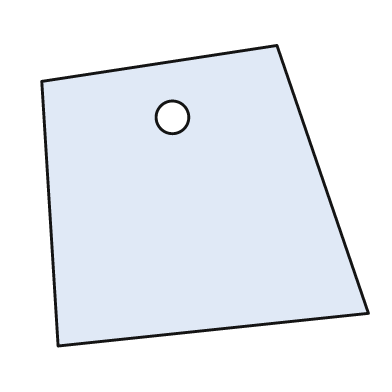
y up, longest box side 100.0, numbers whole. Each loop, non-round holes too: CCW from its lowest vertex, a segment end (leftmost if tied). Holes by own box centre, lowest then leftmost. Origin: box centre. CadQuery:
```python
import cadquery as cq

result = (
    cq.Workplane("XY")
    .moveTo(-45.0, -46.0)
    .lineTo(50.0, -36.0)
    .lineTo(22.0, 46.0)
    .lineTo(-50.0, 35.0)
    .close()
    .moveTo(-10.0, 24.0)
    .circle(5.0)
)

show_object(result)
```